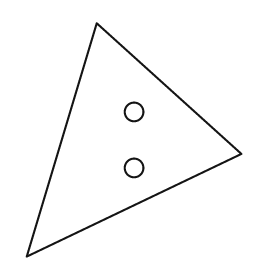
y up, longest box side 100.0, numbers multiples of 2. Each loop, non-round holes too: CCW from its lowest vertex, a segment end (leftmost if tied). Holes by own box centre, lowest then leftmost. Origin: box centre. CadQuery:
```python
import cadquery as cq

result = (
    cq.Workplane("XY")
    .moveTo(-46.0, -50.0)
    .lineTo(46.0, -6.0)
    .lineTo(-16.0, 50.0)
    .close()
    .moveTo(0.0, -12.0)
    .circle(4.0)
    .moveTo(0.0, 12.0)
    .circle(4.0)
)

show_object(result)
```